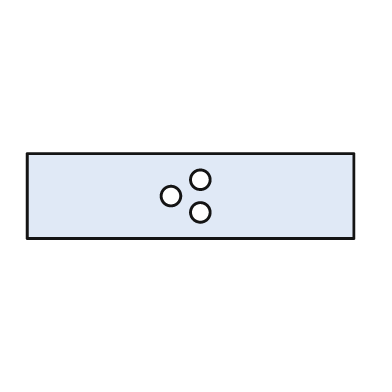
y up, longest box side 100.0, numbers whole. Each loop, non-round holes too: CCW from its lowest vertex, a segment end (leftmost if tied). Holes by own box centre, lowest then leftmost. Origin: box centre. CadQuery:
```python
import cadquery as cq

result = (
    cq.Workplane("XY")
    .moveTo(-50.0, -13.0)
    .lineTo(50.0, -13.0)
    .lineTo(50.0, 13.0)
    .lineTo(-50.0, 13.0)
    .close()
    .moveTo(3.0, -5.0)
    .circle(3.0)
    .moveTo(-6.0, 0.0)
    .circle(3.0)
    .moveTo(3.0, 5.0)
    .circle(3.0)
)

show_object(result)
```